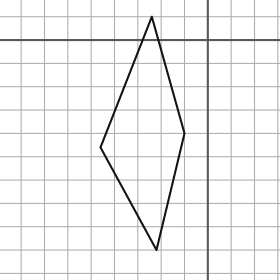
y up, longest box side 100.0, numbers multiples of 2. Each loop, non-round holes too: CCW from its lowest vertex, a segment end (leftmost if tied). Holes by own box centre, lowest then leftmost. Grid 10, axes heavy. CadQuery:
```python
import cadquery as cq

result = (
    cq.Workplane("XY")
    .moveTo(-22.0, -90.0)
    .lineTo(-10.0, -40.0)
    .lineTo(-24.0, 10.0)
    .lineTo(-46.0, -46.0)
    .close()
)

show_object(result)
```